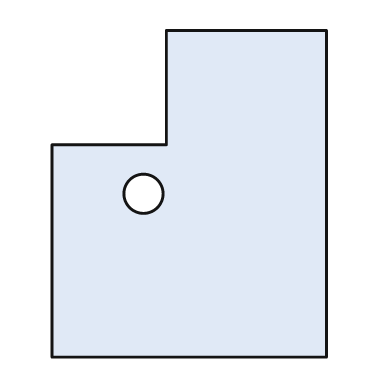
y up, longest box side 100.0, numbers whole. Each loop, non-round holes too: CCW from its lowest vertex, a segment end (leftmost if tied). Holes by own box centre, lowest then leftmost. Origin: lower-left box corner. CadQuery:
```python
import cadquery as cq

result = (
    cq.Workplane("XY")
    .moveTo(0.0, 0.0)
    .lineTo(84.0, 0.0)
    .lineTo(84.0, 100.0)
    .lineTo(35.0, 100.0)
    .lineTo(35.0, 65.0)
    .lineTo(0.0, 65.0)
    .close()
    .moveTo(28.0, 50.0)
    .circle(6.0)
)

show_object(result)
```